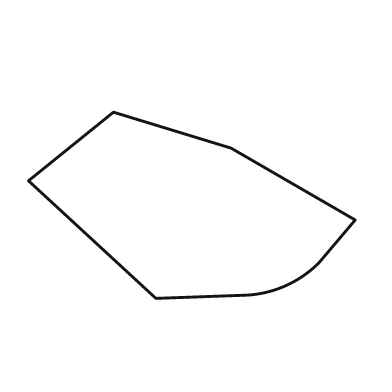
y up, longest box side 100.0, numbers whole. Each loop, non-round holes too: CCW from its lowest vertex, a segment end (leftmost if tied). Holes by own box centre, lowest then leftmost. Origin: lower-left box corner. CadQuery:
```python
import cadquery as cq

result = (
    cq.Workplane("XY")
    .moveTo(39.0, 0.0)
    .lineTo(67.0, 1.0)
    .threePointArc((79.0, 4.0), (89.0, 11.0))
    .lineTo(100.0, 24.0)
    .lineTo(62.0, 46.0)
    .lineTo(26.0, 57.0)
    .lineTo(0.0, 36.0)
    .close()
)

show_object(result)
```